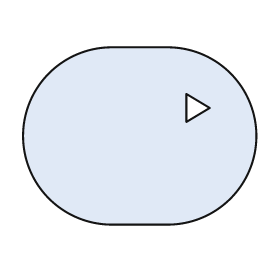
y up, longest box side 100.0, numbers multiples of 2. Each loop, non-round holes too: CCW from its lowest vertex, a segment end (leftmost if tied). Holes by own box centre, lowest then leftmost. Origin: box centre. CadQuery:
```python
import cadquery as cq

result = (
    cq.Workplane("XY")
    .moveTo(-12.0, -38.0)
    .lineTo(12.0, -38.0)
    .threePointArc((50.0, 0.0), (12.0, 38.0))
    .lineTo(-12.0, 38.0)
    .threePointArc((-50.0, 0.0), (-12.0, -38.0))
    .close()
    .moveTo(20.0, 6.0)
    .lineTo(30.0, 12.0)
    .lineTo(20.0, 18.0)
    .close()
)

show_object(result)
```